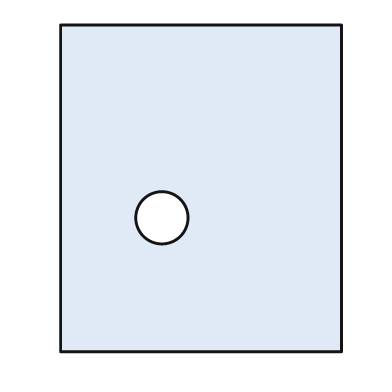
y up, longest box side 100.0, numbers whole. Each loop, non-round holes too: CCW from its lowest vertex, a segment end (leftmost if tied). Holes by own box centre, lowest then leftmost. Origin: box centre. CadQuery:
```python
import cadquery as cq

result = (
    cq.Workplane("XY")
    .moveTo(-43.0, -50.0)
    .lineTo(43.0, -50.0)
    .lineTo(43.0, 50.0)
    .lineTo(-43.0, 50.0)
    .close()
    .moveTo(-12.0, -9.0)
    .circle(8.0)
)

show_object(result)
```